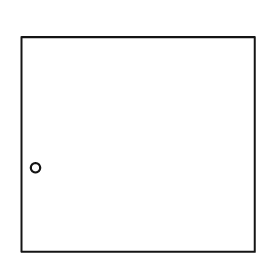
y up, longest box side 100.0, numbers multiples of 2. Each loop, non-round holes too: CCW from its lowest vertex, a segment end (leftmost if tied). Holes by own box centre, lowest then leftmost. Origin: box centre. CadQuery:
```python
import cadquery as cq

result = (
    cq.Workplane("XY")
    .moveTo(-50.0, -46.0)
    .lineTo(50.0, -46.0)
    .lineTo(50.0, 46.0)
    .lineTo(-50.0, 46.0)
    .close()
    .moveTo(-44.0, -10.0)
    .circle(2.0)
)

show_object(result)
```